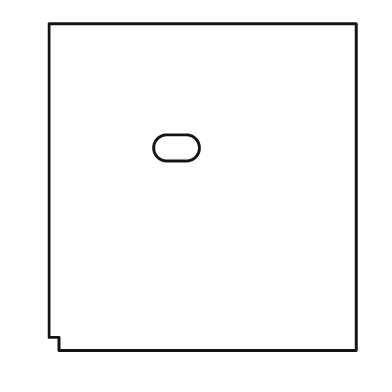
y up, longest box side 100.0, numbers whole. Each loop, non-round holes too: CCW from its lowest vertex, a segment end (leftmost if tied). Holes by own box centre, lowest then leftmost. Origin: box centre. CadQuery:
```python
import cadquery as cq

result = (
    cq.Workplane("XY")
    .moveTo(-44.0, -50.0)
    .lineTo(47.0, -50.0)
    .lineTo(47.0, 50.0)
    .lineTo(-47.0, 50.0)
    .lineTo(-47.0, -46.0)
    .lineTo(-44.0, -46.0)
    .close()
    .moveTo(-11.0, 8.0)
    .lineTo(-5.0, 8.0)
    .threePointArc((-1.0, 12.0), (-5.0, 16.0))
    .lineTo(-11.0, 16.0)
    .threePointArc((-15.0, 12.0), (-11.0, 8.0))
    .close()
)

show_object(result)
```